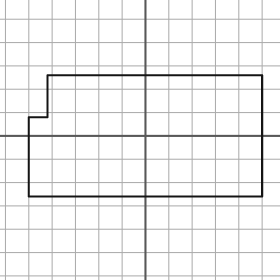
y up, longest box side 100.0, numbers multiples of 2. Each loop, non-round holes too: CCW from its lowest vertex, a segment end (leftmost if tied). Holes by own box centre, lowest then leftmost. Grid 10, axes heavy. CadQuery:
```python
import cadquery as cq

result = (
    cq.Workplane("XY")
    .moveTo(-50.0, -26.0)
    .lineTo(50.0, -26.0)
    .lineTo(50.0, 26.0)
    .lineTo(-42.0, 26.0)
    .lineTo(-42.0, 8.0)
    .lineTo(-50.0, 8.0)
    .close()
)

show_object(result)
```